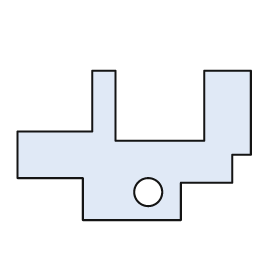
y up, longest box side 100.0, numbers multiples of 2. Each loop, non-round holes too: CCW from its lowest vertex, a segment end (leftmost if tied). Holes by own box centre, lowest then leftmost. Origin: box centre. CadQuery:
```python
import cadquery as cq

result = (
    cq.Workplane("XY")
    .moveTo(-22.0, -32.0)
    .lineTo(20.0, -32.0)
    .lineTo(20.0, -16.0)
    .lineTo(42.0, -16.0)
    .lineTo(42.0, -4.0)
    .lineTo(50.0, -4.0)
    .lineTo(50.0, 32.0)
    .lineTo(30.0, 32.0)
    .lineTo(30.0, 2.0)
    .lineTo(-8.0, 2.0)
    .lineTo(-8.0, 32.0)
    .lineTo(-18.0, 32.0)
    .lineTo(-18.0, 6.0)
    .lineTo(-50.0, 6.0)
    .lineTo(-50.0, -14.0)
    .lineTo(-22.0, -14.0)
    .close()
    .moveTo(6.0, -20.0)
    .circle(6.0)
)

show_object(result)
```